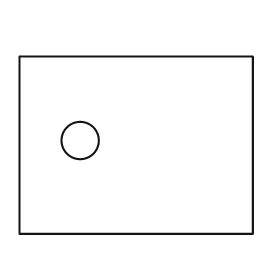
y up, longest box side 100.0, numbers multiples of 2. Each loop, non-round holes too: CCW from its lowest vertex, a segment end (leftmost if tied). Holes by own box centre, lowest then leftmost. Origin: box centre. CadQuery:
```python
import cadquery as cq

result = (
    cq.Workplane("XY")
    .moveTo(-50.0, -38.0)
    .lineTo(50.0, -38.0)
    .lineTo(50.0, 38.0)
    .lineTo(-50.0, 38.0)
    .close()
    .moveTo(-24.0, 2.0)
    .circle(8.0)
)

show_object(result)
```